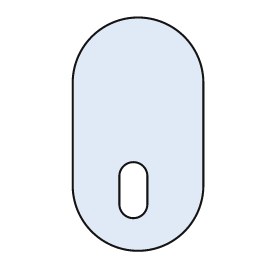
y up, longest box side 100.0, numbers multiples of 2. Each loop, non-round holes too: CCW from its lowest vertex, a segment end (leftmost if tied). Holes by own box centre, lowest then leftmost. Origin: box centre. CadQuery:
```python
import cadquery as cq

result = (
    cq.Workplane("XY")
    .moveTo(-28.0, -22.0)
    .threePointArc((0.0, -50.0), (28.0, -22.0))
    .lineTo(28.0, 22.0)
    .threePointArc((0.0, 50.0), (-28.0, 22.0))
    .close()
    .moveTo(-8.0, -30.0)
    .threePointArc((-2.0, -36.0), (4.0, -30.0))
    .lineTo(4.0, -18.0)
    .threePointArc((-2.0, -12.0), (-8.0, -18.0))
    .close()
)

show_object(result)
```